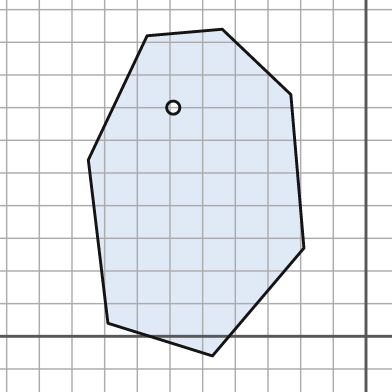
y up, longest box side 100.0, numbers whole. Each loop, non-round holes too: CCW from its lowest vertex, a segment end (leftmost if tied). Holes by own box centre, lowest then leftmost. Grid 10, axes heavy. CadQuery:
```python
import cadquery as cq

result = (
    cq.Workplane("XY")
    .moveTo(-47.0, -6.0)
    .lineTo(-19.0, 27.0)
    .lineTo(-23.0, 74.0)
    .lineTo(-44.0, 94.0)
    .lineTo(-67.0, 92.0)
    .lineTo(-85.0, 54.0)
    .lineTo(-79.0, 4.0)
    .close()
    .moveTo(-59.0, 70.0)
    .circle(2.0)
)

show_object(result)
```